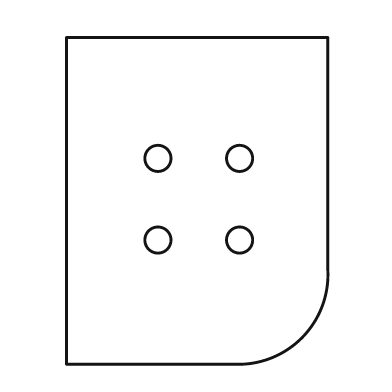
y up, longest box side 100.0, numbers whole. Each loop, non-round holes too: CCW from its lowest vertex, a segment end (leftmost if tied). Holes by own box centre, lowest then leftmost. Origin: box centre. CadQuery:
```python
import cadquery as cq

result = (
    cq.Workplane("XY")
    .moveTo(-40.0, -50.0)
    .lineTo(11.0, -50.0)
    .threePointArc((32.0, -42.0), (40.0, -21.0))
    .lineTo(40.0, 50.0)
    .lineTo(-40.0, 50.0)
    .close()
    .moveTo(-12.0, -12.0)
    .circle(4.0)
    .moveTo(13.0, -12.0)
    .circle(4.0)
    .moveTo(-12.0, 13.0)
    .circle(4.0)
    .moveTo(13.0, 13.0)
    .circle(4.0)
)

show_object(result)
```